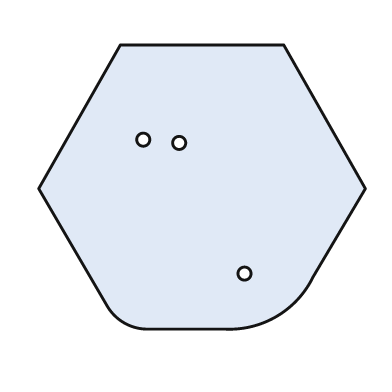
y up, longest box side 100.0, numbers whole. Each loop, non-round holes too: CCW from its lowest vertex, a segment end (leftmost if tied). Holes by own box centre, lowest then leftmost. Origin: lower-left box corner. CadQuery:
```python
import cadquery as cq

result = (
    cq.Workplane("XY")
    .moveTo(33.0, 0.0)
    .lineTo(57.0, 0.0)
    .threePointArc((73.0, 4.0), (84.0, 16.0))
    .lineTo(100.0, 43.0)
    .lineTo(75.0, 87.0)
    .lineTo(25.0, 87.0)
    .lineTo(0.0, 43.0)
    .lineTo(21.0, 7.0)
    .threePointArc((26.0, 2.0), (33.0, 0.0))
    .close()
    .moveTo(63.0, 17.0)
    .circle(2.0)
    .moveTo(43.0, 57.0)
    .circle(2.0)
    .moveTo(32.0, 58.0)
    .circle(2.0)
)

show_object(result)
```